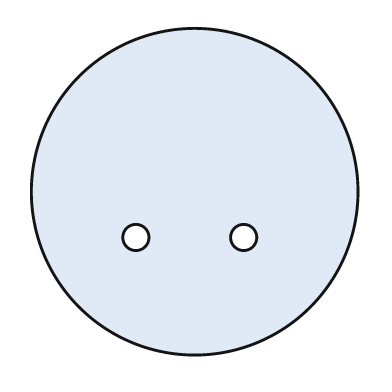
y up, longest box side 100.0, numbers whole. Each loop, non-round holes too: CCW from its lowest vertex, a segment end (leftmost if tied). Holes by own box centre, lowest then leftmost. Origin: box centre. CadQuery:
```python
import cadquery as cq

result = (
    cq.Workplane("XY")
    .moveTo(0.0, 0.0)
    .circle(50.0)
    .moveTo(-18.0, -14.0)
    .circle(4.0)
    .moveTo(15.0, -14.0)
    .circle(4.0)
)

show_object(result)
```